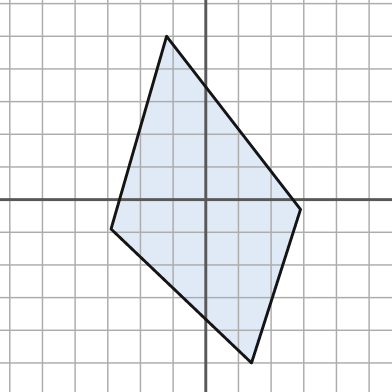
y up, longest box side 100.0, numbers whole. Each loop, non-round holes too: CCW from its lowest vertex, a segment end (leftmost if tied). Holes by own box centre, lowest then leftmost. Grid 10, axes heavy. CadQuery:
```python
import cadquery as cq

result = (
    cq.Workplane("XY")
    .moveTo(14.0, -50.0)
    .lineTo(29.0, -3.0)
    .lineTo(-12.0, 50.0)
    .lineTo(-29.0, -9.0)
    .close()
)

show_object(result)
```